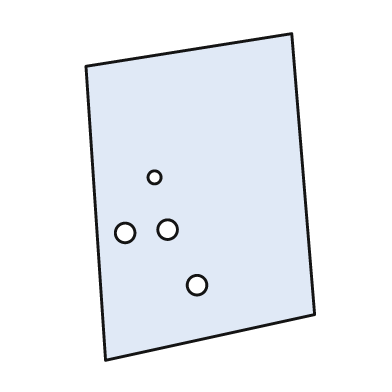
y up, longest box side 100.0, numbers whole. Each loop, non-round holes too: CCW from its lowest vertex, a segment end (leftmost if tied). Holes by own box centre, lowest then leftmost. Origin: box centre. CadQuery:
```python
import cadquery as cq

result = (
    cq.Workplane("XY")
    .moveTo(-29.0, -50.0)
    .lineTo(35.0, -36.0)
    .lineTo(28.0, 50.0)
    .lineTo(-35.0, 40.0)
    .close()
    .moveTo(-1.0, -27.0)
    .circle(3.0)
    .moveTo(-23.0, -11.0)
    .circle(3.0)
    .moveTo(-10.0, -10.0)
    .circle(3.0)
    .moveTo(-14.0, 6.0)
    .circle(2.0)
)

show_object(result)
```